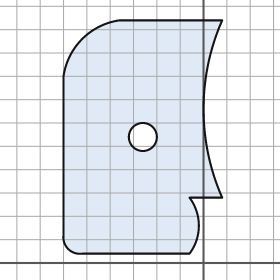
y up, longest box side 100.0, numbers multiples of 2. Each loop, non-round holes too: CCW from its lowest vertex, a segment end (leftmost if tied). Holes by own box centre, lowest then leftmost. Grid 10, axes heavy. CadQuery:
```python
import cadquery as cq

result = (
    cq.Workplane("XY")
    .moveTo(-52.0, 4.0)
    .lineTo(-6.0, 4.0)
    .threePointArc((-2.0, 16.0), (-6.0, 28.0))
    .lineTo(8.0, 28.0)
    .threePointArc((0.0, 66.0), (8.0, 104.0))
    .lineTo(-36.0, 104.0)
    .threePointArc((-52.0, 96.0), (-60.0, 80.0))
    .lineTo(-60.0, 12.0)
    .threePointArc((-58.0, 6.0), (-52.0, 4.0))
    .close()
    .moveTo(-26.0, 54.0)
    .circle(6.0)
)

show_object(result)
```